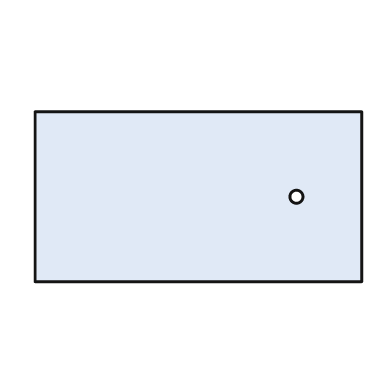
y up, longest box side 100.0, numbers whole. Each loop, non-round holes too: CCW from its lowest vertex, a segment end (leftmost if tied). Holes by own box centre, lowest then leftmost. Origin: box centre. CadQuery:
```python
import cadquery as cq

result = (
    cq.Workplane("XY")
    .moveTo(-50.0, -26.0)
    .lineTo(50.0, -26.0)
    .lineTo(50.0, 26.0)
    .lineTo(-50.0, 26.0)
    .close()
    .moveTo(30.0, 0.0)
    .circle(2.0)
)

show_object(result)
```